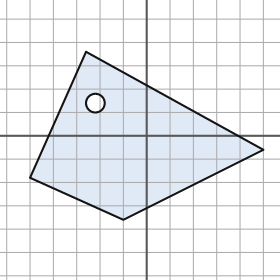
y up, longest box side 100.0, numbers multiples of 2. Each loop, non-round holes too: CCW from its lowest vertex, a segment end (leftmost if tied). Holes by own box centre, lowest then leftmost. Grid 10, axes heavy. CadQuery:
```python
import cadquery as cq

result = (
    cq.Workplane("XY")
    .moveTo(-10.0, -36.0)
    .lineTo(50.0, -6.0)
    .lineTo(-26.0, 36.0)
    .lineTo(-50.0, -18.0)
    .close()
    .moveTo(-22.0, 14.0)
    .circle(4.0)
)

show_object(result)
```